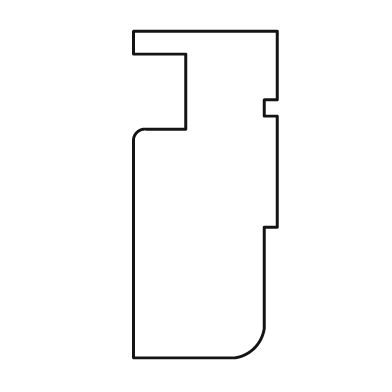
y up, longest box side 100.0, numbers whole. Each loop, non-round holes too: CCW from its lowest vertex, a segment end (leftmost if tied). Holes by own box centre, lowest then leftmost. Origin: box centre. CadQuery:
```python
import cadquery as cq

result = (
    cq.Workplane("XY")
    .moveTo(-22.0, -50.0)
    .lineTo(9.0, -50.0)
    .threePointArc((15.0, -47.0), (18.0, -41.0))
    .lineTo(18.0, -10.0)
    .lineTo(22.0, -10.0)
    .lineTo(22.0, 24.0)
    .lineTo(18.0, 24.0)
    .lineTo(18.0, 29.0)
    .lineTo(22.0, 29.0)
    .lineTo(22.0, 50.0)
    .lineTo(-22.0, 50.0)
    .lineTo(-22.0, 43.0)
    .lineTo(-6.0, 43.0)
    .lineTo(-6.0, 20.0)
    .lineTo(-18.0, 20.0)
    .threePointArc((-21.0, 19.0), (-22.0, 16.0))
    .close()
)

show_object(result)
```